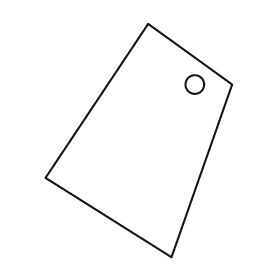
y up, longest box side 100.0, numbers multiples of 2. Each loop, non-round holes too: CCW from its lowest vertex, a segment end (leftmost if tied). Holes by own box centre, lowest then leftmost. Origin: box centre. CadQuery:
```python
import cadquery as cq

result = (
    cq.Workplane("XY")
    .moveTo(14.0, -50.0)
    .lineTo(40.0, 24.0)
    .lineTo(4.0, 50.0)
    .lineTo(-40.0, -16.0)
    .close()
    .moveTo(24.0, 24.0)
    .circle(4.0)
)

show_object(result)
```